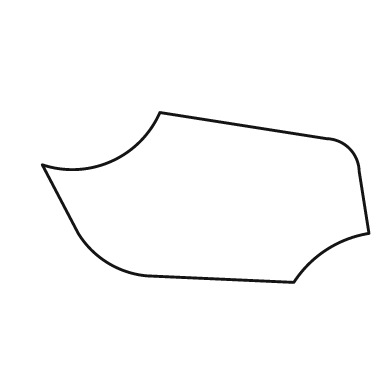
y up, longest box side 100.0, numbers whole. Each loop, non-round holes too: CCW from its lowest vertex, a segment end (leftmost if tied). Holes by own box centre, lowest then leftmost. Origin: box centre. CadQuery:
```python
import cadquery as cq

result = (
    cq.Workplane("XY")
    .moveTo(27.0, -26.0)
    .threePointArc((37.0, -16.0), (50.0, -11.0))
    .lineTo(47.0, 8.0)
    .threePointArc((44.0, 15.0), (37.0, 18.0))
    .lineTo(-14.0, 26.0)
    .threePointArc((-29.0, 11.0), (-50.0, 10.0))
    .lineTo(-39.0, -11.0)
    .threePointArc((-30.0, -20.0), (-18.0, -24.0))
    .close()
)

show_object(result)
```